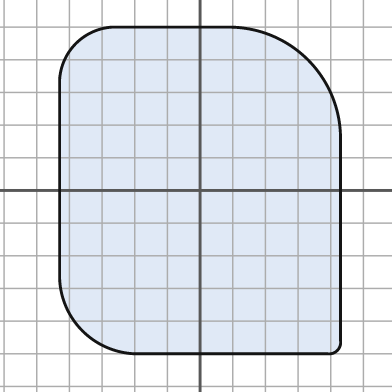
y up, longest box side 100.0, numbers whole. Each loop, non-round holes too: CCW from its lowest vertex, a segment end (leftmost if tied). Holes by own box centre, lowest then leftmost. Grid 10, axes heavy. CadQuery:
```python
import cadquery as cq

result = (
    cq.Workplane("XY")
    .moveTo(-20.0, -50.0)
    .lineTo(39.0, -50.0)
    .threePointArc((42.0, -49.0), (43.0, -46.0))
    .lineTo(43.0, 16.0)
    .threePointArc((33.0, 40.0), (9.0, 50.0))
    .lineTo(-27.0, 50.0)
    .threePointArc((-38.0, 45.0), (-43.0, 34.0))
    .lineTo(-43.0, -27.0)
    .threePointArc((-36.0, -43.0), (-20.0, -50.0))
    .close()
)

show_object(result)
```